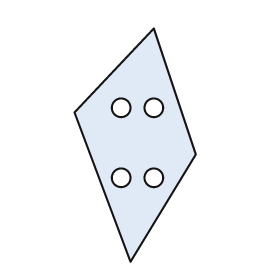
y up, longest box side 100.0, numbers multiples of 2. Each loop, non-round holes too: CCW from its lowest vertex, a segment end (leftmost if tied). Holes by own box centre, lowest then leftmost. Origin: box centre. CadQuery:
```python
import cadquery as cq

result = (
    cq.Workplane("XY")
    .moveTo(-2.0, -50.0)
    .lineTo(26.0, -4.0)
    .lineTo(8.0, 50.0)
    .lineTo(-26.0, 14.0)
    .close()
    .moveTo(-6.0, -14.0)
    .circle(4.0)
    .moveTo(8.0, -14.0)
    .circle(4.0)
    .moveTo(-6.0, 16.0)
    .circle(4.0)
    .moveTo(8.0, 16.0)
    .circle(4.0)
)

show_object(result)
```